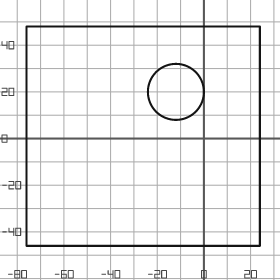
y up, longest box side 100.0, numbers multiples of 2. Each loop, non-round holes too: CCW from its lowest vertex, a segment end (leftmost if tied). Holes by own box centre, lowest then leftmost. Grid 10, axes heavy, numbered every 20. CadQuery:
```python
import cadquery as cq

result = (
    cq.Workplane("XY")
    .moveTo(-76.0, -46.0)
    .lineTo(24.0, -46.0)
    .lineTo(24.0, 48.0)
    .lineTo(-76.0, 48.0)
    .close()
    .moveTo(-12.0, 20.0)
    .circle(12.0)
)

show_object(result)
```